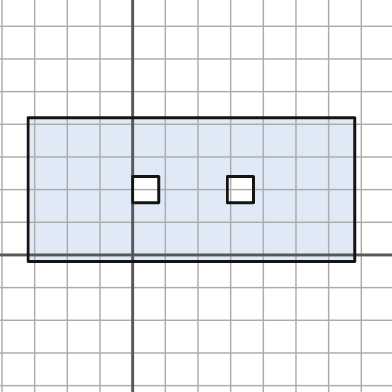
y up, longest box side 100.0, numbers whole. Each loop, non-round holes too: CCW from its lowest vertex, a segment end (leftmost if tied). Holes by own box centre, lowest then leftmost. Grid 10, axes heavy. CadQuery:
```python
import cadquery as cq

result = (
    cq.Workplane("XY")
    .moveTo(-32.0, -2.0)
    .lineTo(68.0, -2.0)
    .lineTo(68.0, 42.0)
    .lineTo(-32.0, 42.0)
    .close()
    .moveTo(0.0, 16.0)
    .lineTo(8.0, 16.0)
    .lineTo(8.0, 24.0)
    .lineTo(0.0, 24.0)
    .close()
    .moveTo(29.0, 16.0)
    .lineTo(37.0, 16.0)
    .lineTo(37.0, 24.0)
    .lineTo(29.0, 24.0)
    .close()
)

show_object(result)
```